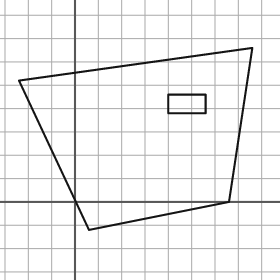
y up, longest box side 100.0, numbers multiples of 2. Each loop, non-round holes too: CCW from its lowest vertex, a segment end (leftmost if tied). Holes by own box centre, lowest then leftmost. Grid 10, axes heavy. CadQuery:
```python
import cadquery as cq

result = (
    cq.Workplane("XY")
    .moveTo(6.0, -12.0)
    .lineTo(66.0, 0.0)
    .lineTo(76.0, 66.0)
    .lineTo(-24.0, 52.0)
    .close()
    .moveTo(40.0, 38.0)
    .lineTo(56.0, 38.0)
    .lineTo(56.0, 46.0)
    .lineTo(40.0, 46.0)
    .close()
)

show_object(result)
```